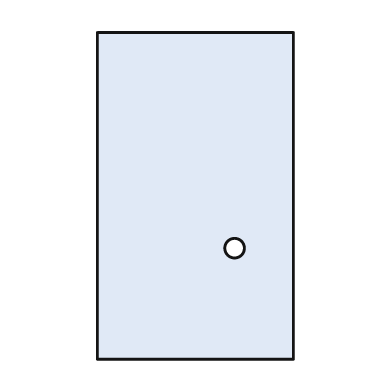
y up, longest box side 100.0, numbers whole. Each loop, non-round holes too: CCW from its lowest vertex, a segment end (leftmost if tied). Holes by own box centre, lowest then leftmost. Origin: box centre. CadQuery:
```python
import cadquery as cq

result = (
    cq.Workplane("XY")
    .moveTo(-30.0, -50.0)
    .lineTo(30.0, -50.0)
    .lineTo(30.0, 50.0)
    .lineTo(-30.0, 50.0)
    .close()
    .moveTo(12.0, -16.0)
    .circle(3.0)
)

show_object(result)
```